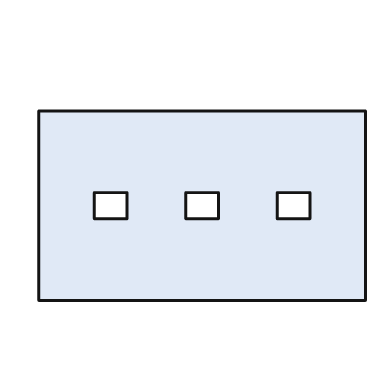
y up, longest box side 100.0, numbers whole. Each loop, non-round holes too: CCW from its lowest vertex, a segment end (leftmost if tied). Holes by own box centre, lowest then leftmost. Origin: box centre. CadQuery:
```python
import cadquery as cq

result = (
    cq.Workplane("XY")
    .moveTo(-50.0, -29.0)
    .lineTo(50.0, -29.0)
    .lineTo(50.0, 29.0)
    .lineTo(-50.0, 29.0)
    .close()
    .moveTo(-33.0, -4.0)
    .lineTo(-23.0, -4.0)
    .lineTo(-23.0, 4.0)
    .lineTo(-33.0, 4.0)
    .close()
    .moveTo(-5.0, -4.0)
    .lineTo(5.0, -4.0)
    .lineTo(5.0, 4.0)
    .lineTo(-5.0, 4.0)
    .close()
    .moveTo(23.0, -4.0)
    .lineTo(33.0, -4.0)
    .lineTo(33.0, 4.0)
    .lineTo(23.0, 4.0)
    .close()
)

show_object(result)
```